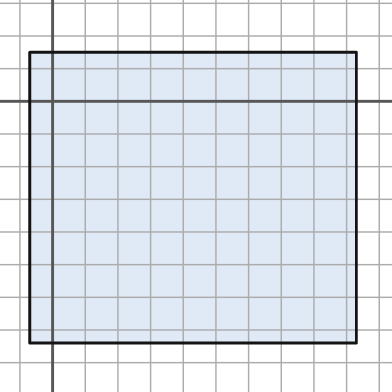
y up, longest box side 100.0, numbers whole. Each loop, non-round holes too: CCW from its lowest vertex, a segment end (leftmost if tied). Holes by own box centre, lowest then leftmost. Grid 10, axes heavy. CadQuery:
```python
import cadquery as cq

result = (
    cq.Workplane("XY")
    .moveTo(-7.0, -74.0)
    .lineTo(93.0, -74.0)
    .lineTo(93.0, 15.0)
    .lineTo(-7.0, 15.0)
    .close()
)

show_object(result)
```